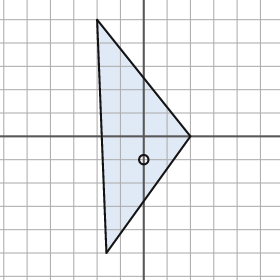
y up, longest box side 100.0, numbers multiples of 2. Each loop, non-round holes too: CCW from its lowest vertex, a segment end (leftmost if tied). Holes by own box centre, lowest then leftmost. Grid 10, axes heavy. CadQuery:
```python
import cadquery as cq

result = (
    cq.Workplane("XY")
    .moveTo(-16.0, -50.0)
    .lineTo(20.0, 0.0)
    .lineTo(-20.0, 50.0)
    .close()
    .moveTo(0.0, -10.0)
    .circle(2.0)
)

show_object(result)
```